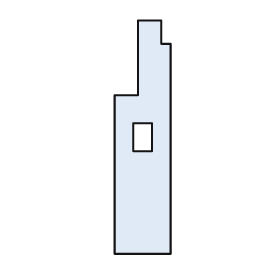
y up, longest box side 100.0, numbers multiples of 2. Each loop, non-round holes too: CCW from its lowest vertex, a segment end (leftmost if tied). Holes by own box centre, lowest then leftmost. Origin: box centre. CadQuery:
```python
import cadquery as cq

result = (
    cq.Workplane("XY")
    .moveTo(-12.0, -50.0)
    .lineTo(12.0, -50.0)
    .lineTo(12.0, 40.0)
    .lineTo(8.0, 40.0)
    .lineTo(8.0, 50.0)
    .lineTo(-2.0, 50.0)
    .lineTo(-2.0, 18.0)
    .lineTo(-12.0, 18.0)
    .close()
    .moveTo(-4.0, -6.0)
    .lineTo(4.0, -6.0)
    .lineTo(4.0, 6.0)
    .lineTo(-4.0, 6.0)
    .close()
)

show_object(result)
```